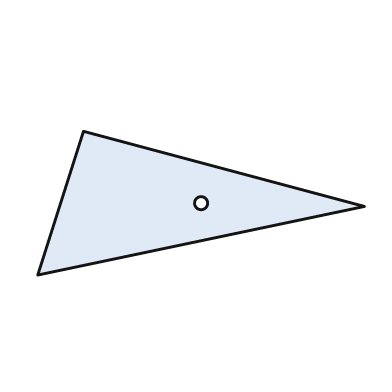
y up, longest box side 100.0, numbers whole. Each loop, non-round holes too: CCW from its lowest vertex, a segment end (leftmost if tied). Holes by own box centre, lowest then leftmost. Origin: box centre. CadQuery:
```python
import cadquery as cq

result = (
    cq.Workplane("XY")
    .moveTo(-50.0, -22.0)
    .lineTo(50.0, -1.0)
    .lineTo(-36.0, 22.0)
    .close()
    .moveTo(0.0, 0.0)
    .circle(2.0)
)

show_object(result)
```